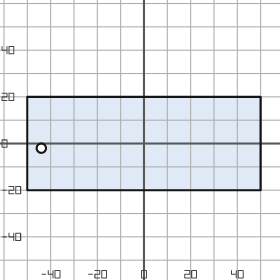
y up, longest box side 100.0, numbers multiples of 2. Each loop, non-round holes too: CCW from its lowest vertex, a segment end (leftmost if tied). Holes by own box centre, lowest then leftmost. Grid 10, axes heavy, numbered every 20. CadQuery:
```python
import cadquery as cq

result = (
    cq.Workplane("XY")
    .moveTo(-50.0, -20.0)
    .lineTo(50.0, -20.0)
    .lineTo(50.0, 20.0)
    .lineTo(-50.0, 20.0)
    .close()
    .moveTo(-44.0, -2.0)
    .circle(2.0)
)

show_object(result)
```